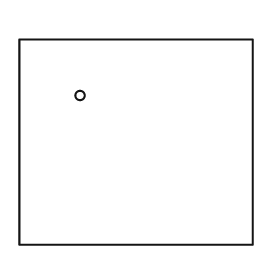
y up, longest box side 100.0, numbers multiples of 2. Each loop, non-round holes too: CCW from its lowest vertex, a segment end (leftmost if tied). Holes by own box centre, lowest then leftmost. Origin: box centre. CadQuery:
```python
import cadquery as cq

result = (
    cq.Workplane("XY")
    .moveTo(-50.0, -44.0)
    .lineTo(50.0, -44.0)
    .lineTo(50.0, 44.0)
    .lineTo(-50.0, 44.0)
    .close()
    .moveTo(-24.0, 20.0)
    .circle(2.0)
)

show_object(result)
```